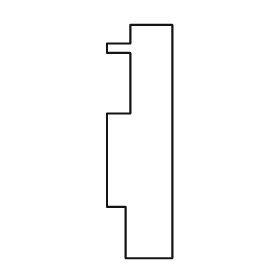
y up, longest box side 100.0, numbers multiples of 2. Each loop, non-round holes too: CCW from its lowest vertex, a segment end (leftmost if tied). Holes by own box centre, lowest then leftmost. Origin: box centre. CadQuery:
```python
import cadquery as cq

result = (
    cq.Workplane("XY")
    .moveTo(-6.0, -50.0)
    .lineTo(14.0, -50.0)
    .lineTo(14.0, 50.0)
    .lineTo(-4.0, 50.0)
    .lineTo(-4.0, 42.0)
    .lineTo(-14.0, 42.0)
    .lineTo(-14.0, 38.0)
    .lineTo(-4.0, 38.0)
    .lineTo(-4.0, 12.0)
    .lineTo(-14.0, 12.0)
    .lineTo(-14.0, -28.0)
    .lineTo(-6.0, -28.0)
    .close()
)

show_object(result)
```